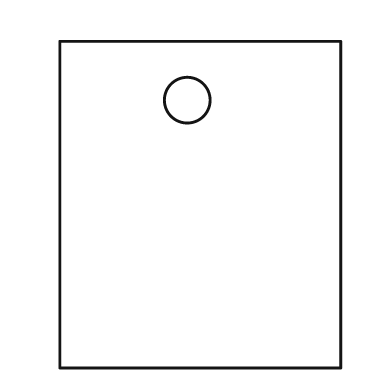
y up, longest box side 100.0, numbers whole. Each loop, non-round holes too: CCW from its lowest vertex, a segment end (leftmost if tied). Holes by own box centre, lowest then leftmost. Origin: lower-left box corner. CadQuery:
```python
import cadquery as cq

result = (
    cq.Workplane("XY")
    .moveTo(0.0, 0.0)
    .lineTo(86.0, 0.0)
    .lineTo(86.0, 100.0)
    .lineTo(0.0, 100.0)
    .close()
    .moveTo(39.0, 82.0)
    .circle(7.0)
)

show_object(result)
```